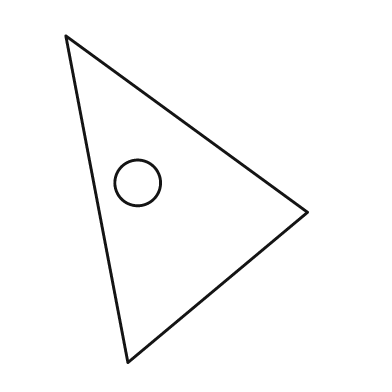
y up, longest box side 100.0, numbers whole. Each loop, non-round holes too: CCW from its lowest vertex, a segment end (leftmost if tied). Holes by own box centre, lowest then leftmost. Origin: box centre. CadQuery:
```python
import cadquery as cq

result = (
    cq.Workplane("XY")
    .moveTo(-18.0, -50.0)
    .lineTo(37.0, -4.0)
    .lineTo(-37.0, 50.0)
    .close()
    .moveTo(-15.0, 5.0)
    .circle(7.0)
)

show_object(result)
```